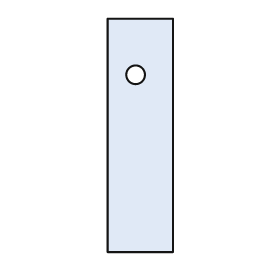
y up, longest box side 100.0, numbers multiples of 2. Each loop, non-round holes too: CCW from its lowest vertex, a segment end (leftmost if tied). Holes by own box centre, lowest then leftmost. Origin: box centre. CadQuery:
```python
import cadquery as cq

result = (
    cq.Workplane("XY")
    .moveTo(-14.0, -50.0)
    .lineTo(14.0, -50.0)
    .lineTo(14.0, 50.0)
    .lineTo(-14.0, 50.0)
    .close()
    .moveTo(-2.0, 26.0)
    .circle(4.0)
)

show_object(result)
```